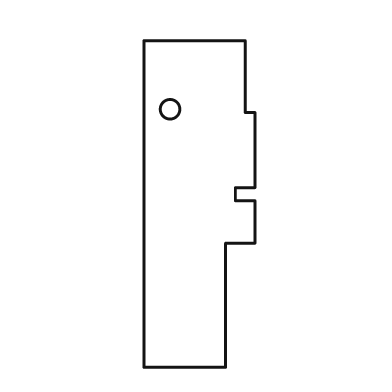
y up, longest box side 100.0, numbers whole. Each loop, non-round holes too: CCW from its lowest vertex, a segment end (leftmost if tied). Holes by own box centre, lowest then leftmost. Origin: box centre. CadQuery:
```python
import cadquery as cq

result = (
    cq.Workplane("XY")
    .moveTo(-17.0, -50.0)
    .lineTo(8.0, -50.0)
    .lineTo(8.0, -12.0)
    .lineTo(17.0, -12.0)
    .lineTo(17.0, 1.0)
    .lineTo(11.0, 1.0)
    .lineTo(11.0, 5.0)
    .lineTo(17.0, 5.0)
    .lineTo(17.0, 28.0)
    .lineTo(14.0, 28.0)
    .lineTo(14.0, 50.0)
    .lineTo(-17.0, 50.0)
    .close()
    .moveTo(-9.0, 29.0)
    .circle(3.0)
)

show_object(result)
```